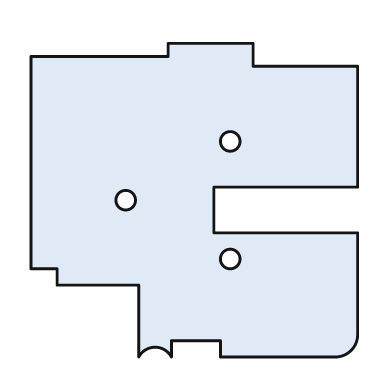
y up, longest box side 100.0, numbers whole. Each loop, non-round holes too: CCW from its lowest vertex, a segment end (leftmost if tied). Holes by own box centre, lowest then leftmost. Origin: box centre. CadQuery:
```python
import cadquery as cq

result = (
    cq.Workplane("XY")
    .moveTo(-17.0, -48.0)
    .threePointArc((-12.0, -45.0), (-7.0, -48.0))
    .lineTo(-7.0, -43.0)
    .lineTo(8.0, -43.0)
    .lineTo(8.0, -48.0)
    .lineTo(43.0, -48.0)
    .threePointArc((48.0, -46.0), (50.0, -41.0))
    .lineTo(50.0, -10.0)
    .lineTo(6.0, -10.0)
    .lineTo(6.0, 4.0)
    .lineTo(50.0, 4.0)
    .lineTo(50.0, 41.0)
    .lineTo(18.0, 41.0)
    .lineTo(18.0, 48.0)
    .lineTo(-8.0, 48.0)
    .lineTo(-8.0, 44.0)
    .lineTo(-50.0, 44.0)
    .lineTo(-50.0, -21.0)
    .lineTo(-42.0, -21.0)
    .lineTo(-42.0, -26.0)
    .lineTo(-17.0, -26.0)
    .close()
    .moveTo(11.0, -18.0)
    .circle(3.0)
    .moveTo(-21.0, 0.0)
    .circle(3.0)
    .moveTo(11.0, 18.0)
    .circle(3.0)
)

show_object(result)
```